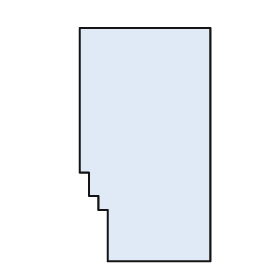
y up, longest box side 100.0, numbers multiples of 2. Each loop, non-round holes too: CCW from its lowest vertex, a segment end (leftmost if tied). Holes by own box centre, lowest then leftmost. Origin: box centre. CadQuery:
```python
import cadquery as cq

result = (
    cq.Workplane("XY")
    .moveTo(-16.0, -50.0)
    .lineTo(28.0, -50.0)
    .lineTo(28.0, 50.0)
    .lineTo(-28.0, 50.0)
    .lineTo(-28.0, -12.0)
    .lineTo(-24.0, -12.0)
    .lineTo(-24.0, -22.0)
    .lineTo(-20.0, -22.0)
    .lineTo(-20.0, -28.0)
    .lineTo(-16.0, -28.0)
    .close()
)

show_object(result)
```